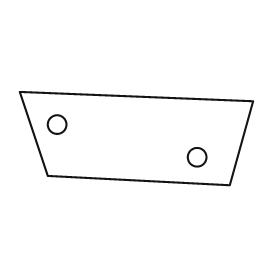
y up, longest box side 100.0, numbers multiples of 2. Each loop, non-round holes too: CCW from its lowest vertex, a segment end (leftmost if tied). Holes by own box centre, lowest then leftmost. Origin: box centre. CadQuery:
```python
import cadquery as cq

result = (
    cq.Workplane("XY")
    .moveTo(40.0, -20.0)
    .lineTo(50.0, 16.0)
    .lineTo(-50.0, 20.0)
    .lineTo(-38.0, -16.0)
    .close()
    .moveTo(26.0, -8.0)
    .circle(4.0)
    .moveTo(-34.0, 6.0)
    .circle(4.0)
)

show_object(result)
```